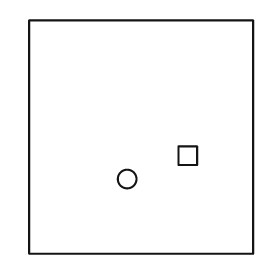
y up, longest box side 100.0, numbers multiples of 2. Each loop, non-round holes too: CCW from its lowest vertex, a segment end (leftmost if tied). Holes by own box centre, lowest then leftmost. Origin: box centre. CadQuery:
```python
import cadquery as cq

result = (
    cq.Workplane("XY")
    .moveTo(-48.0, -50.0)
    .lineTo(48.0, -50.0)
    .lineTo(48.0, 50.0)
    .lineTo(-48.0, 50.0)
    .close()
    .moveTo(-6.0, -18.0)
    .circle(4.0)
    .moveTo(16.0, -12.0)
    .lineTo(24.0, -12.0)
    .lineTo(24.0, -4.0)
    .lineTo(16.0, -4.0)
    .close()
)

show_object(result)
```